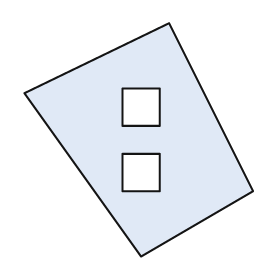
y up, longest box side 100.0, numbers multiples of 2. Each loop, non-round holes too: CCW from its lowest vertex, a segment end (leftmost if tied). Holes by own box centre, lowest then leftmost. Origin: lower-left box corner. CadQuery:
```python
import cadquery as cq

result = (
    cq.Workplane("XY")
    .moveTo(50.0, 0.0)
    .lineTo(98.0, 28.0)
    .lineTo(62.0, 100.0)
    .lineTo(0.0, 70.0)
    .close()
    .moveTo(42.0, 28.0)
    .lineTo(58.0, 28.0)
    .lineTo(58.0, 44.0)
    .lineTo(42.0, 44.0)
    .close()
    .moveTo(42.0, 56.0)
    .lineTo(58.0, 56.0)
    .lineTo(58.0, 72.0)
    .lineTo(42.0, 72.0)
    .close()
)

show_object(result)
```